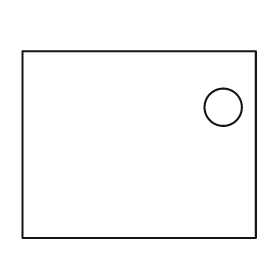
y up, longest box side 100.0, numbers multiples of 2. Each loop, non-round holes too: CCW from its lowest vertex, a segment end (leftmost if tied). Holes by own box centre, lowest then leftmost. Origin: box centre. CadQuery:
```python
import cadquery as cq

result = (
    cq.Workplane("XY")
    .moveTo(-50.0, -40.0)
    .lineTo(50.0, -40.0)
    .lineTo(50.0, 40.0)
    .lineTo(-50.0, 40.0)
    .close()
    .moveTo(36.0, 16.0)
    .circle(8.0)
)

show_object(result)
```